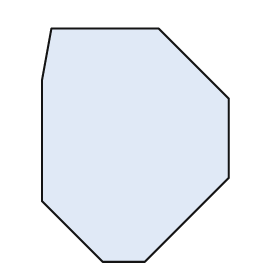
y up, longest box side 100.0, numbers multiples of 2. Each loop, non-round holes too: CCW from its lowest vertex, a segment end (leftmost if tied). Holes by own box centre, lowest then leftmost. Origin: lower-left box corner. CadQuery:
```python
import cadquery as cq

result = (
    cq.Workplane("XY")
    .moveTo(26.0, 0.0)
    .lineTo(44.0, 0.0)
    .lineTo(80.0, 36.0)
    .lineTo(80.0, 70.0)
    .lineTo(50.0, 100.0)
    .lineTo(4.0, 100.0)
    .lineTo(0.0, 78.0)
    .lineTo(0.0, 26.0)
    .close()
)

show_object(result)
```